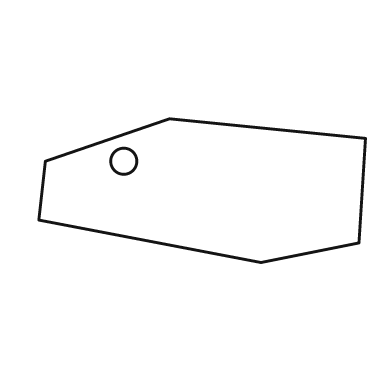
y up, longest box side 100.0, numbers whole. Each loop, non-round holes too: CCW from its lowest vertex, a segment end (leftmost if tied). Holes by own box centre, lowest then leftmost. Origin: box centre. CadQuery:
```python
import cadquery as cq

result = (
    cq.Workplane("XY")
    .moveTo(18.0, -22.0)
    .lineTo(48.0, -16.0)
    .lineTo(50.0, 16.0)
    .lineTo(-10.0, 22.0)
    .lineTo(-48.0, 9.0)
    .lineTo(-50.0, -9.0)
    .close()
    .moveTo(-24.0, 9.0)
    .circle(4.0)
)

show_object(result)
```